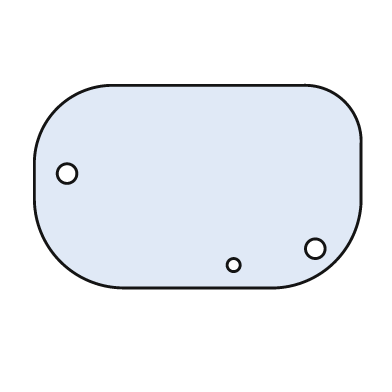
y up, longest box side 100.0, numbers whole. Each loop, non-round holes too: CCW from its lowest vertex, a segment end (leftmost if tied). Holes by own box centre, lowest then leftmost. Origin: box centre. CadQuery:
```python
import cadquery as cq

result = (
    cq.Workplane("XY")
    .moveTo(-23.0, -31.0)
    .lineTo(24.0, -31.0)
    .threePointArc((42.0, -23.0), (50.0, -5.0))
    .lineTo(50.0, 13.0)
    .threePointArc((45.0, 26.0), (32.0, 31.0))
    .lineTo(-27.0, 31.0)
    .threePointArc((-43.0, 24.0), (-50.0, 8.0))
    .lineTo(-50.0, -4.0)
    .threePointArc((-42.0, -23.0), (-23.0, -31.0))
    .close()
    .moveTo(11.0, -24.0)
    .circle(2.0)
    .moveTo(36.0, -19.0)
    .circle(3.0)
    .moveTo(-40.0, 4.0)
    .circle(3.0)
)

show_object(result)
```